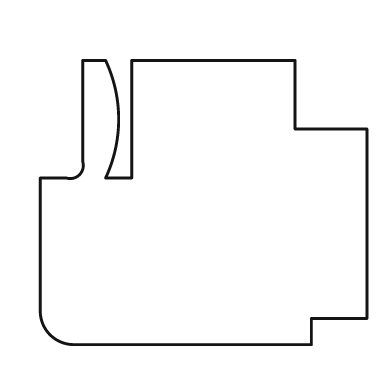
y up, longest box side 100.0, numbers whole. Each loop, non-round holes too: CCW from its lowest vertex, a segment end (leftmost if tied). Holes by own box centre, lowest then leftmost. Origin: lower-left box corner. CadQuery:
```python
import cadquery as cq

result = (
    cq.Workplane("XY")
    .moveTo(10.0, 0.0)
    .lineTo(83.0, 0.0)
    .lineTo(83.0, 8.0)
    .lineTo(100.0, 8.0)
    .lineTo(100.0, 66.0)
    .lineTo(78.0, 66.0)
    .lineTo(78.0, 87.0)
    .lineTo(28.0, 87.0)
    .lineTo(28.0, 51.0)
    .lineTo(20.0, 51.0)
    .threePointArc((24.0, 69.0), (20.0, 87.0))
    .lineTo(13.0, 87.0)
    .lineTo(13.0, 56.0)
    .threePointArc((12.0, 52.0), (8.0, 51.0))
    .lineTo(0.0, 51.0)
    .lineTo(0.0, 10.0)
    .threePointArc((3.0, 3.0), (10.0, 0.0))
    .close()
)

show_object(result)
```